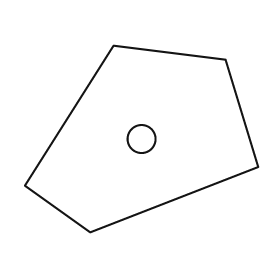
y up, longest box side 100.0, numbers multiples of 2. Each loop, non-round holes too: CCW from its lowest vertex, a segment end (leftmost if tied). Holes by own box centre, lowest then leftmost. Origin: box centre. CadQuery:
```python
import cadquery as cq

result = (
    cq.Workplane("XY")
    .moveTo(-22.0, -40.0)
    .lineTo(50.0, -12.0)
    .lineTo(36.0, 34.0)
    .lineTo(-12.0, 40.0)
    .lineTo(-50.0, -20.0)
    .close()
    .moveTo(0.0, 0.0)
    .circle(6.0)
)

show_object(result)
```